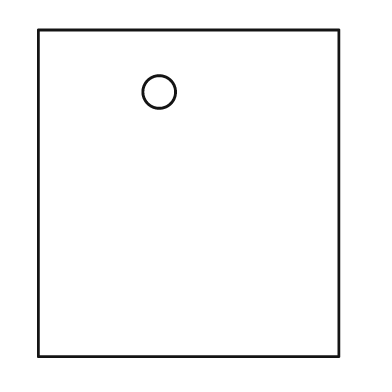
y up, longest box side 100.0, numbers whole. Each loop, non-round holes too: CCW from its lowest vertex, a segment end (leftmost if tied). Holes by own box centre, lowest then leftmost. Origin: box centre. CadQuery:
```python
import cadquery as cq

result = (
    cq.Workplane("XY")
    .moveTo(-46.0, -50.0)
    .lineTo(46.0, -50.0)
    .lineTo(46.0, 50.0)
    .lineTo(-46.0, 50.0)
    .close()
    .moveTo(-9.0, 31.0)
    .circle(5.0)
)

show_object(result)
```